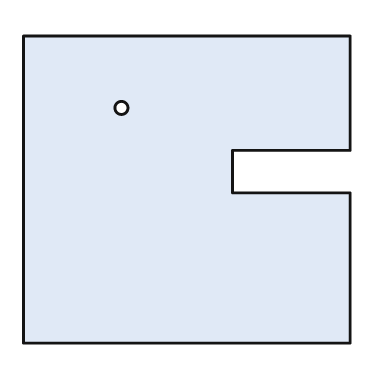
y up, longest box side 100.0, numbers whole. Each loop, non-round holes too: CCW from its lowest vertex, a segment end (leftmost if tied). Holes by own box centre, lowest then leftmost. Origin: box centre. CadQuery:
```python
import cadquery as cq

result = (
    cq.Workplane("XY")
    .moveTo(-50.0, -47.0)
    .lineTo(50.0, -47.0)
    .lineTo(50.0, -1.0)
    .lineTo(14.0, -1.0)
    .lineTo(14.0, 12.0)
    .lineTo(50.0, 12.0)
    .lineTo(50.0, 47.0)
    .lineTo(-50.0, 47.0)
    .close()
    .moveTo(-20.0, 25.0)
    .circle(2.0)
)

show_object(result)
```